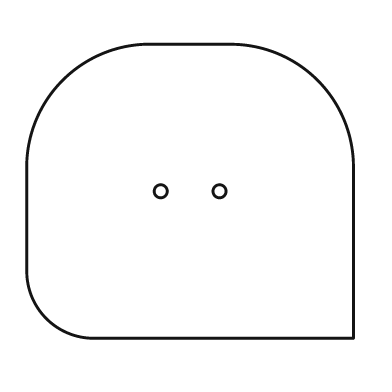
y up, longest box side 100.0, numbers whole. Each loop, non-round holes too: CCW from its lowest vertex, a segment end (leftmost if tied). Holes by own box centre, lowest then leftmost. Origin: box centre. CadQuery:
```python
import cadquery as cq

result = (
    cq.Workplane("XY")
    .moveTo(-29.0, -45.0)
    .lineTo(50.0, -45.0)
    .lineTo(50.0, 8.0)
    .threePointArc((39.0, 34.0), (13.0, 45.0))
    .lineTo(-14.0, 45.0)
    .threePointArc((-39.0, 34.0), (-50.0, 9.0))
    .lineTo(-50.0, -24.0)
    .threePointArc((-44.0, -39.0), (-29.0, -45.0))
    .close()
    .moveTo(-9.0, 0.0)
    .circle(2.0)
    .moveTo(9.0, 0.0)
    .circle(2.0)
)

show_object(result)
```